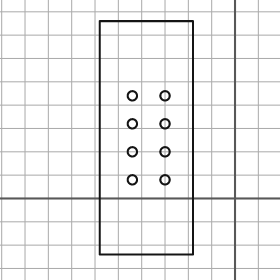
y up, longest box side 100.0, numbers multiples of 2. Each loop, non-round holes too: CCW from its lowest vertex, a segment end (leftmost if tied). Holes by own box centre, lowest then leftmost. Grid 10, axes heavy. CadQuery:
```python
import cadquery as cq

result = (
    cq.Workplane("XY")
    .moveTo(-58.0, -24.0)
    .lineTo(-18.0, -24.0)
    .lineTo(-18.0, 76.0)
    .lineTo(-58.0, 76.0)
    .close()
    .moveTo(-44.0, 8.0)
    .circle(2.0)
    .moveTo(-30.0, 8.0)
    .circle(2.0)
    .moveTo(-44.0, 20.0)
    .circle(2.0)
    .moveTo(-30.0, 20.0)
    .circle(2.0)
    .moveTo(-44.0, 32.0)
    .circle(2.0)
    .moveTo(-30.0, 32.0)
    .circle(2.0)
    .moveTo(-44.0, 44.0)
    .circle(2.0)
    .moveTo(-30.0, 44.0)
    .circle(2.0)
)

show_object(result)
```